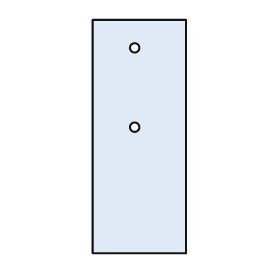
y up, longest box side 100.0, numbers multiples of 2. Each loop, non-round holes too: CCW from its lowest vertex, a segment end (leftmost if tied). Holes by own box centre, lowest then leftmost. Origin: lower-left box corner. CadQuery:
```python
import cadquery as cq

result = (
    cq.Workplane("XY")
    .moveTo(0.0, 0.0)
    .lineTo(40.0, 0.0)
    .lineTo(40.0, 100.0)
    .lineTo(0.0, 100.0)
    .close()
    .moveTo(18.0, 54.0)
    .circle(2.0)
    .moveTo(18.0, 88.0)
    .circle(2.0)
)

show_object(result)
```